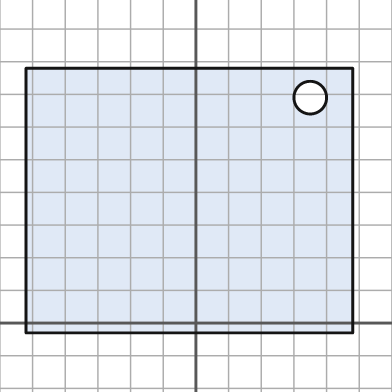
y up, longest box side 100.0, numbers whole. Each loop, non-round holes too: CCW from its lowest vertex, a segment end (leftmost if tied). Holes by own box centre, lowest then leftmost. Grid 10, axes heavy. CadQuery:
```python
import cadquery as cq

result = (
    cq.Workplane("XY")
    .moveTo(-52.0, -3.0)
    .lineTo(48.0, -3.0)
    .lineTo(48.0, 78.0)
    .lineTo(-52.0, 78.0)
    .close()
    .moveTo(35.0, 69.0)
    .circle(5.0)
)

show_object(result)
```